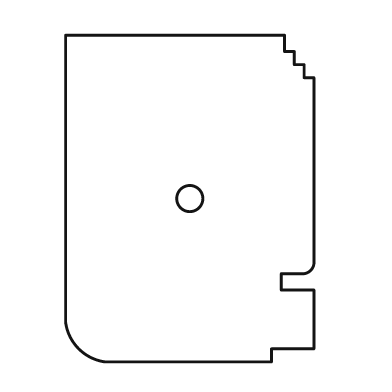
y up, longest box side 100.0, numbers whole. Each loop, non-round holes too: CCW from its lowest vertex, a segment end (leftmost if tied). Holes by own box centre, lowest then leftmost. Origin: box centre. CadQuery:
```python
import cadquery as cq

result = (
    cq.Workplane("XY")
    .moveTo(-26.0, -50.0)
    .lineTo(25.0, -50.0)
    .lineTo(25.0, -46.0)
    .lineTo(38.0, -46.0)
    .lineTo(38.0, -28.0)
    .lineTo(28.0, -28.0)
    .lineTo(28.0, -23.0)
    .lineTo(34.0, -23.0)
    .threePointArc((37.0, -22.0), (38.0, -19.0))
    .lineTo(38.0, 37.0)
    .lineTo(35.0, 37.0)
    .lineTo(35.0, 41.0)
    .lineTo(32.0, 41.0)
    .lineTo(32.0, 45.0)
    .lineTo(29.0, 45.0)
    .lineTo(29.0, 50.0)
    .lineTo(-38.0, 50.0)
    .lineTo(-38.0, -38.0)
    .threePointArc((-34.0, -46.0), (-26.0, -50.0))
    .close()
    .moveTo(0.0, 0.0)
    .circle(4.0)
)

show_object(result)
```